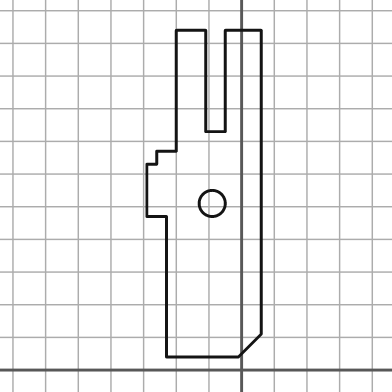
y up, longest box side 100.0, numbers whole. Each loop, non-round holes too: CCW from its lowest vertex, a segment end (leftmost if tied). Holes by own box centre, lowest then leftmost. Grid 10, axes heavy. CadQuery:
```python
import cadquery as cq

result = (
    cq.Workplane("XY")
    .moveTo(-23.0, 4.0)
    .lineTo(-1.0, 4.0)
    .lineTo(6.0, 11.0)
    .lineTo(6.0, 104.0)
    .lineTo(-5.0, 104.0)
    .lineTo(-5.0, 73.0)
    .lineTo(-11.0, 73.0)
    .lineTo(-11.0, 104.0)
    .lineTo(-20.0, 104.0)
    .lineTo(-20.0, 67.0)
    .lineTo(-26.0, 67.0)
    .lineTo(-26.0, 63.0)
    .lineTo(-29.0, 63.0)
    .lineTo(-29.0, 47.0)
    .lineTo(-23.0, 47.0)
    .close()
    .moveTo(-9.0, 51.0)
    .circle(4.0)
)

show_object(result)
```